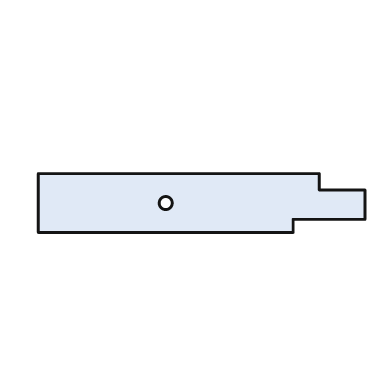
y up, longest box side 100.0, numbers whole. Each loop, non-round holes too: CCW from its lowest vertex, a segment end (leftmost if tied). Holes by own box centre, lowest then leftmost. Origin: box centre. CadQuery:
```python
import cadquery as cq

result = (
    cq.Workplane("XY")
    .moveTo(-50.0, -9.0)
    .lineTo(28.0, -9.0)
    .lineTo(28.0, -5.0)
    .lineTo(50.0, -5.0)
    .lineTo(50.0, 4.0)
    .lineTo(36.0, 4.0)
    .lineTo(36.0, 9.0)
    .lineTo(-50.0, 9.0)
    .close()
    .moveTo(-11.0, 0.0)
    .circle(2.0)
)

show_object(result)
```